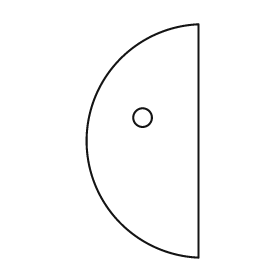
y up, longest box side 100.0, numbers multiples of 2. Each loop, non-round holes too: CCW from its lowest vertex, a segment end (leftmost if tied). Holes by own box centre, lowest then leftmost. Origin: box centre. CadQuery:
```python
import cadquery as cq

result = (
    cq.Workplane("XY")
    .moveTo(24.0, -50.0)
    .lineTo(24.0, 50.0)
    .threePointArc((-24.0, 0.0), (24.0, -50.0))
    .close()
    .moveTo(0.0, 10.0)
    .circle(4.0)
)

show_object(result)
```